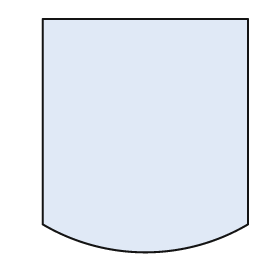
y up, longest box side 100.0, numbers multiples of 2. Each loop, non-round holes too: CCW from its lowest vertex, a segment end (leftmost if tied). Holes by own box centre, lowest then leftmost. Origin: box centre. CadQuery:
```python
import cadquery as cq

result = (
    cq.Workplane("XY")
    .moveTo(-44.0, -38.0)
    .threePointArc((0.0, -50.0), (44.0, -38.0))
    .lineTo(44.0, 50.0)
    .lineTo(-44.0, 50.0)
    .close()
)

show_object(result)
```